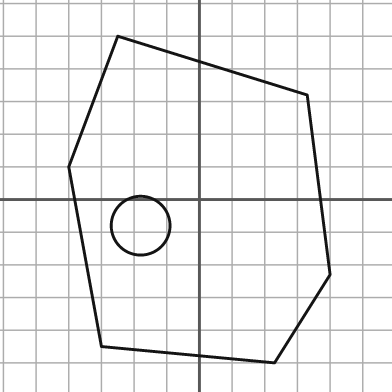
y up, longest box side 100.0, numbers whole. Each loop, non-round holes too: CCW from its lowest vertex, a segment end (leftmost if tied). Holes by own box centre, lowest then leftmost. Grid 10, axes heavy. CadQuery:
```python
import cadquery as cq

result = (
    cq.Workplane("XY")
    .moveTo(23.0, -50.0)
    .lineTo(40.0, -23.0)
    .lineTo(33.0, 32.0)
    .lineTo(-25.0, 50.0)
    .lineTo(-40.0, 10.0)
    .lineTo(-30.0, -45.0)
    .close()
    .moveTo(-18.0, -8.0)
    .circle(9.0)
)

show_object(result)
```